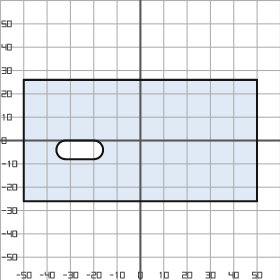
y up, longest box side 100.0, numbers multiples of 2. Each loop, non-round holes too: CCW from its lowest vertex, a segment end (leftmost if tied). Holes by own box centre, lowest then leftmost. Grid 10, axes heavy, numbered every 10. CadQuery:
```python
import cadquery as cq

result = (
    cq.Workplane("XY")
    .moveTo(-50.0, -26.0)
    .lineTo(50.0, -26.0)
    .lineTo(50.0, 26.0)
    .lineTo(-50.0, 26.0)
    .close()
    .moveTo(-32.0, -8.0)
    .lineTo(-20.0, -8.0)
    .threePointArc((-16.0, -4.0), (-20.0, 0.0))
    .lineTo(-32.0, 0.0)
    .threePointArc((-36.0, -4.0), (-32.0, -8.0))
    .close()
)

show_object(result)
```